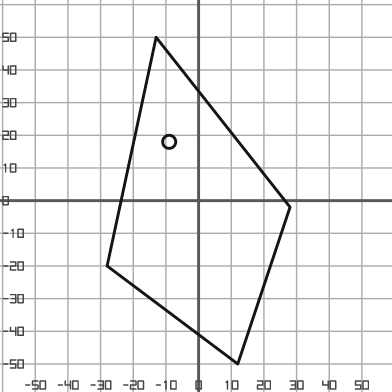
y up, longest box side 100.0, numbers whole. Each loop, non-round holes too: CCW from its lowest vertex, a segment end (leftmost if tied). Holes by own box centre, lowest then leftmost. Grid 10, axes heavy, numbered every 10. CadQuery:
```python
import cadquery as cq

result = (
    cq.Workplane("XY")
    .moveTo(12.0, -50.0)
    .lineTo(28.0, -2.0)
    .lineTo(-13.0, 50.0)
    .lineTo(-28.0, -20.0)
    .close()
    .moveTo(-9.0, 18.0)
    .circle(2.0)
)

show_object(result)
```